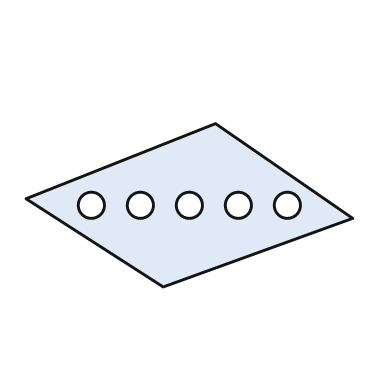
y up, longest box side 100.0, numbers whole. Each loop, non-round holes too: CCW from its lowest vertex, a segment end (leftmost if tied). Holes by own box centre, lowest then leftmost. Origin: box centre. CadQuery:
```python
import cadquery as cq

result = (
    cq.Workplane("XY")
    .moveTo(-8.0, -25.0)
    .lineTo(50.0, -4.0)
    .lineTo(8.0, 25.0)
    .lineTo(-50.0, 2.0)
    .close()
    .moveTo(-30.0, 0.0)
    .circle(4.0)
    .moveTo(-15.0, 0.0)
    .circle(4.0)
    .moveTo(0.0, 0.0)
    .circle(4.0)
    .moveTo(15.0, 0.0)
    .circle(4.0)
    .moveTo(30.0, 0.0)
    .circle(4.0)
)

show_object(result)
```